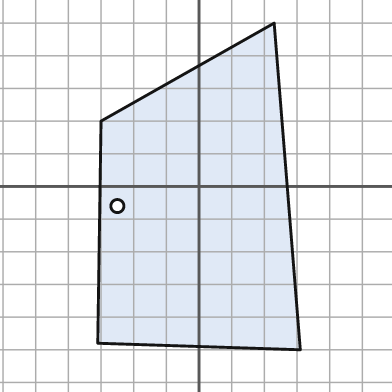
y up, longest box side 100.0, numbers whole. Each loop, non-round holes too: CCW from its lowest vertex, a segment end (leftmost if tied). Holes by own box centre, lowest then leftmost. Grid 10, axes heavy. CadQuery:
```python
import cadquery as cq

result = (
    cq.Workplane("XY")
    .moveTo(31.0, -50.0)
    .lineTo(23.0, 50.0)
    .lineTo(-30.0, 20.0)
    .lineTo(-31.0, -48.0)
    .close()
    .moveTo(-25.0, -6.0)
    .circle(2.0)
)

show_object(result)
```